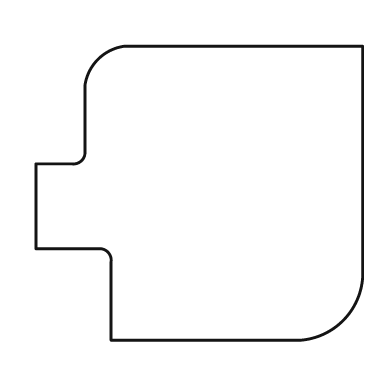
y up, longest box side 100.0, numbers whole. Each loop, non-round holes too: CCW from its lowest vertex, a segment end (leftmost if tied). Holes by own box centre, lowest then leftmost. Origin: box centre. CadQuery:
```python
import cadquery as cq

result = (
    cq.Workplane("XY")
    .moveTo(-27.0, -45.0)
    .lineTo(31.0, -45.0)
    .threePointArc((44.0, -39.0), (50.0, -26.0))
    .lineTo(50.0, 45.0)
    .lineTo(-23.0, 45.0)
    .threePointArc((-31.0, 41.0), (-35.0, 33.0))
    .lineTo(-35.0, 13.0)
    .threePointArc((-36.0, 10.0), (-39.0, 9.0))
    .lineTo(-50.0, 9.0)
    .lineTo(-50.0, -17.0)
    .lineTo(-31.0, -17.0)
    .threePointArc((-28.0, -18.0), (-27.0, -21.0))
    .close()
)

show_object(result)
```